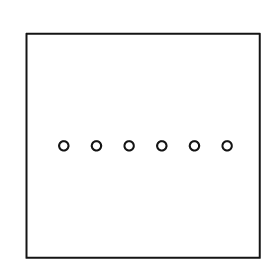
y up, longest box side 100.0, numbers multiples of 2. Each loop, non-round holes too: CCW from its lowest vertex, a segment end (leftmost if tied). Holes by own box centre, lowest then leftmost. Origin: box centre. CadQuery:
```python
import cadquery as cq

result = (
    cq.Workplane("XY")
    .moveTo(-50.0, -48.0)
    .lineTo(50.0, -48.0)
    .lineTo(50.0, 48.0)
    .lineTo(-50.0, 48.0)
    .close()
    .moveTo(-34.0, 0.0)
    .circle(2.0)
    .moveTo(-20.0, 0.0)
    .circle(2.0)
    .moveTo(-6.0, 0.0)
    .circle(2.0)
    .moveTo(8.0, 0.0)
    .circle(2.0)
    .moveTo(22.0, 0.0)
    .circle(2.0)
    .moveTo(36.0, 0.0)
    .circle(2.0)
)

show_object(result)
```